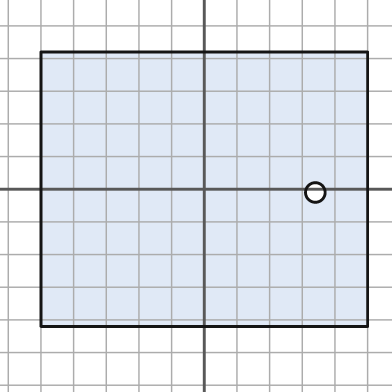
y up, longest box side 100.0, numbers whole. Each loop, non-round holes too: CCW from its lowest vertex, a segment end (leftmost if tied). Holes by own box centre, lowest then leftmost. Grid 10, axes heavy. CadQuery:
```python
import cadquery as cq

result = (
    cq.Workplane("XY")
    .moveTo(-50.0, -42.0)
    .lineTo(50.0, -42.0)
    .lineTo(50.0, 42.0)
    .lineTo(-50.0, 42.0)
    .close()
    .moveTo(34.0, -1.0)
    .circle(3.0)
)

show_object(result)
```